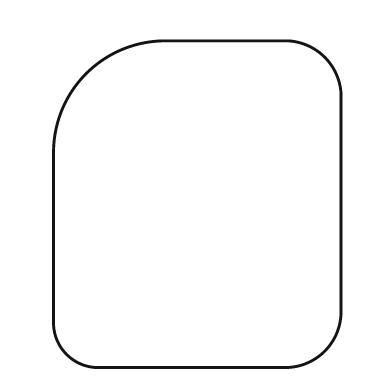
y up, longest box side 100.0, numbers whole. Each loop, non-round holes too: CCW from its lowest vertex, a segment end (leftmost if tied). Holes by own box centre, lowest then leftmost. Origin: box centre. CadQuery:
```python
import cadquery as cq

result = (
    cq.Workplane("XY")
    .moveTo(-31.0, -50.0)
    .lineTo(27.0, -50.0)
    .threePointArc((39.0, -45.0), (44.0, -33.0))
    .lineTo(44.0, 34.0)
    .threePointArc((39.0, 45.0), (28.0, 50.0))
    .lineTo(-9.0, 50.0)
    .threePointArc((-34.0, 40.0), (-44.0, 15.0))
    .lineTo(-44.0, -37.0)
    .threePointArc((-40.0, -46.0), (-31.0, -50.0))
    .close()
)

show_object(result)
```